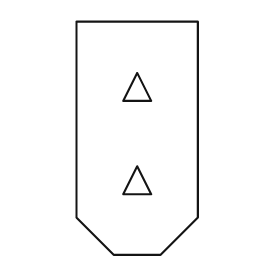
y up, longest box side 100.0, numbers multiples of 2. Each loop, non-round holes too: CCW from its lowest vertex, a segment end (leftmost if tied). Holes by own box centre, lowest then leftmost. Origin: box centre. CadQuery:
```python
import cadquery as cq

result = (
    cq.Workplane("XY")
    .moveTo(-10.0, -50.0)
    .lineTo(10.0, -50.0)
    .lineTo(26.0, -34.0)
    .lineTo(26.0, 50.0)
    .lineTo(-26.0, 50.0)
    .lineTo(-26.0, -34.0)
    .close()
    .moveTo(-6.0, -24.0)
    .lineTo(6.0, -24.0)
    .lineTo(0.0, -12.0)
    .close()
    .moveTo(-6.0, 16.0)
    .lineTo(6.0, 16.0)
    .lineTo(0.0, 28.0)
    .close()
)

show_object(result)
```